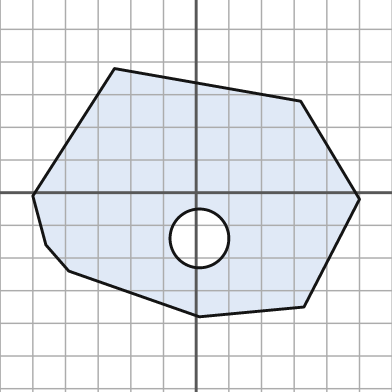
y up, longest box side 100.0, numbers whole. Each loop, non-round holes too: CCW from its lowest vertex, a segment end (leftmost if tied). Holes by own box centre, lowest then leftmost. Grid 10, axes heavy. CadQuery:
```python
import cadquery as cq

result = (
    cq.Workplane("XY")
    .moveTo(1.0, -38.0)
    .lineTo(33.0, -35.0)
    .lineTo(50.0, -2.0)
    .lineTo(32.0, 28.0)
    .lineTo(-25.0, 38.0)
    .lineTo(-50.0, -1.0)
    .lineTo(-46.0, -16.0)
    .lineTo(-39.0, -24.0)
    .close()
    .moveTo(1.0, -14.0)
    .circle(9.0)
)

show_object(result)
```